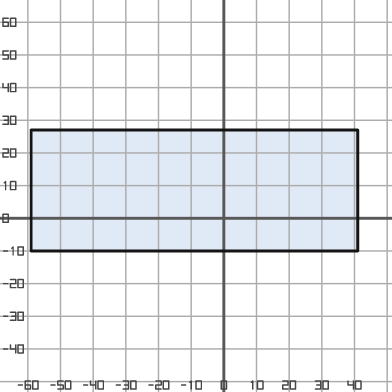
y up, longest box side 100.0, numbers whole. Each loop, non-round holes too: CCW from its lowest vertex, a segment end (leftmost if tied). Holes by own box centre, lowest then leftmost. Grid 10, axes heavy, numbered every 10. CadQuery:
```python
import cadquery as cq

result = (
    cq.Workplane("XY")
    .moveTo(-59.0, -10.0)
    .lineTo(41.0, -10.0)
    .lineTo(41.0, 27.0)
    .lineTo(-59.0, 27.0)
    .close()
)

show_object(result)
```